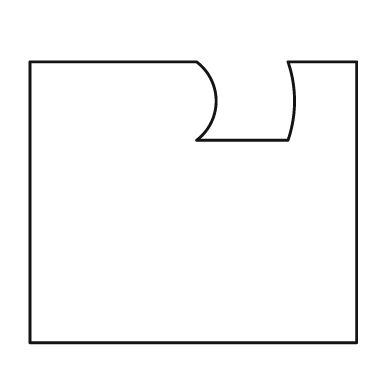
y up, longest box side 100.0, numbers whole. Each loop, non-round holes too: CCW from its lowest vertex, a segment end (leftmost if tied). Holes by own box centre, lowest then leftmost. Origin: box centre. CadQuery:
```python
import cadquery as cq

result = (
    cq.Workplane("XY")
    .moveTo(-50.0, -43.0)
    .lineTo(50.0, -43.0)
    .lineTo(50.0, 43.0)
    .lineTo(29.0, 43.0)
    .threePointArc((31.0, 31.0), (29.0, 19.0))
    .lineTo(1.0, 19.0)
    .threePointArc((7.0, 31.0), (1.0, 43.0))
    .lineTo(-50.0, 43.0)
    .close()
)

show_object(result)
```